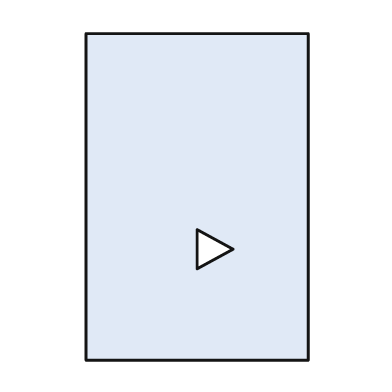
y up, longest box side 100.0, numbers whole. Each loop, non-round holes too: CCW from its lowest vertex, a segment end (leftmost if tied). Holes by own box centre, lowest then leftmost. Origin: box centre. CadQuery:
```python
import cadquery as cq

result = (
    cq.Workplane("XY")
    .moveTo(-34.0, -50.0)
    .lineTo(34.0, -50.0)
    .lineTo(34.0, 50.0)
    .lineTo(-34.0, 50.0)
    .close()
    .moveTo(0.0, -22.0)
    .lineTo(11.0, -16.0)
    .lineTo(0.0, -10.0)
    .close()
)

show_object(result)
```